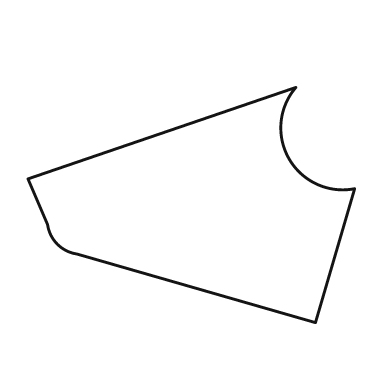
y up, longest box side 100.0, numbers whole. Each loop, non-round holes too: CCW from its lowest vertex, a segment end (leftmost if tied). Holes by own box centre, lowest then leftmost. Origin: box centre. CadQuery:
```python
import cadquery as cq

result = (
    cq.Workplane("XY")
    .moveTo(38.0, -36.0)
    .lineTo(50.0, 5.0)
    .threePointArc((30.0, 14.0), (32.0, 36.0))
    .lineTo(-50.0, 8.0)
    .lineTo(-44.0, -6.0)
    .threePointArc((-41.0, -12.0), (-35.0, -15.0))
    .close()
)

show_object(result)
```